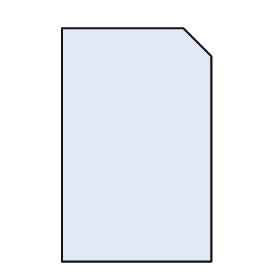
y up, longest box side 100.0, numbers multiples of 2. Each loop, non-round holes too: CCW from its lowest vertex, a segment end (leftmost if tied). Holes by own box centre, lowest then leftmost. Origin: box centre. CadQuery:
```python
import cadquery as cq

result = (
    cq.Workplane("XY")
    .moveTo(-32.0, -50.0)
    .lineTo(32.0, -50.0)
    .lineTo(32.0, 38.0)
    .lineTo(20.0, 50.0)
    .lineTo(-32.0, 50.0)
    .close()
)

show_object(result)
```